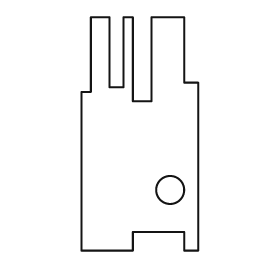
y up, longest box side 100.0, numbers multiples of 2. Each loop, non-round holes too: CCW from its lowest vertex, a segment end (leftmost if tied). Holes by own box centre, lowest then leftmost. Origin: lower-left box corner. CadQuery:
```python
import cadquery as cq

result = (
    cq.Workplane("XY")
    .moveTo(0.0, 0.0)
    .lineTo(22.0, 0.0)
    .lineTo(22.0, 8.0)
    .lineTo(44.0, 8.0)
    .lineTo(44.0, 0.0)
    .lineTo(50.0, 0.0)
    .lineTo(50.0, 72.0)
    .lineTo(44.0, 72.0)
    .lineTo(44.0, 100.0)
    .lineTo(30.0, 100.0)
    .lineTo(30.0, 64.0)
    .lineTo(22.0, 64.0)
    .lineTo(22.0, 100.0)
    .lineTo(18.0, 100.0)
    .lineTo(18.0, 70.0)
    .lineTo(12.0, 70.0)
    .lineTo(12.0, 100.0)
    .lineTo(4.0, 100.0)
    .lineTo(4.0, 68.0)
    .lineTo(0.0, 68.0)
    .close()
    .moveTo(38.0, 26.0)
    .circle(6.0)
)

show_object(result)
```